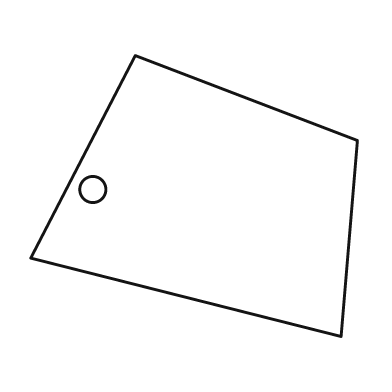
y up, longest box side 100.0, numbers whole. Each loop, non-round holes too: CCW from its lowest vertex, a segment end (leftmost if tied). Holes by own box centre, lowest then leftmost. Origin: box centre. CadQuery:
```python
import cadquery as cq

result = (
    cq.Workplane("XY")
    .moveTo(45.0, -43.0)
    .lineTo(50.0, 17.0)
    .lineTo(-18.0, 43.0)
    .lineTo(-50.0, -19.0)
    .close()
    .moveTo(-31.0, 2.0)
    .circle(4.0)
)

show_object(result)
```